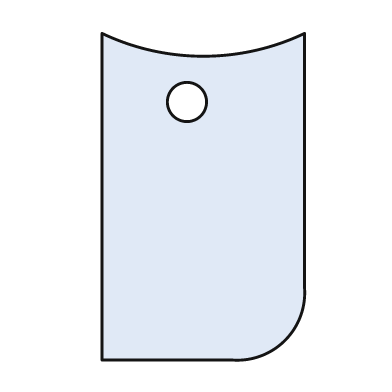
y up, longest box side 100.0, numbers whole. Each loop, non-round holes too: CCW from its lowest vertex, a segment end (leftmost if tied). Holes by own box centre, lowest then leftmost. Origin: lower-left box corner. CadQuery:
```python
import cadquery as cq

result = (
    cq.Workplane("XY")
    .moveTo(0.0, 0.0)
    .lineTo(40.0, 0.0)
    .threePointArc((56.0, 6.0), (62.0, 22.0))
    .lineTo(62.0, 100.0)
    .threePointArc((31.0, 93.0), (0.0, 100.0))
    .close()
    .moveTo(26.0, 79.0)
    .circle(6.0)
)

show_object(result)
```